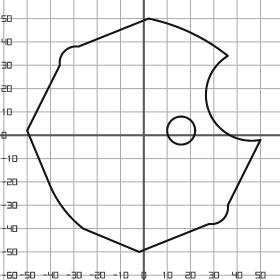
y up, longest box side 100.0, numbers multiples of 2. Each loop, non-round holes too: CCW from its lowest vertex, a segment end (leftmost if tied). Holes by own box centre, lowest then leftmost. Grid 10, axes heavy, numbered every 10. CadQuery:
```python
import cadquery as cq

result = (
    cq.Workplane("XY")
    .moveTo(-2.0, -50.0)
    .lineTo(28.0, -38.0)
    .threePointArc((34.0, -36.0), (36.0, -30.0))
    .lineTo(50.0, -2.0)
    .threePointArc((28.0, 10.0), (36.0, 34.0))
    .threePointArc((20.0, 44.0), (2.0, 50.0))
    .lineTo(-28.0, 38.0)
    .threePointArc((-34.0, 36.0), (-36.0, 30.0))
    .lineTo(-50.0, 2.0)
    .lineTo(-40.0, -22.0)
    .threePointArc((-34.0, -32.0), (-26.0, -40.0))
    .close()
    .moveTo(16.0, 2.0)
    .circle(6.0)
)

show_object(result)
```